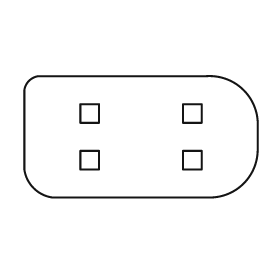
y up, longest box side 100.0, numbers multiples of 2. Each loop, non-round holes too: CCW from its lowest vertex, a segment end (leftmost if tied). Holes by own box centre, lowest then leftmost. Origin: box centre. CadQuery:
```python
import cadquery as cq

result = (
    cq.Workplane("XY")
    .moveTo(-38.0, -26.0)
    .lineTo(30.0, -26.0)
    .threePointArc((44.0, -20.0), (50.0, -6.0))
    .lineTo(50.0, 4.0)
    .threePointArc((44.0, 20.0), (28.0, 26.0))
    .lineTo(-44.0, 26.0)
    .threePointArc((-48.0, 24.0), (-50.0, 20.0))
    .lineTo(-50.0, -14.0)
    .threePointArc((-46.0, -22.0), (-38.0, -26.0))
    .close()
    .moveTo(-26.0, -14.0)
    .lineTo(-18.0, -14.0)
    .lineTo(-18.0, -6.0)
    .lineTo(-26.0, -6.0)
    .close()
    .moveTo(18.0, -14.0)
    .lineTo(26.0, -14.0)
    .lineTo(26.0, -6.0)
    .lineTo(18.0, -6.0)
    .close()
    .moveTo(-26.0, 6.0)
    .lineTo(-18.0, 6.0)
    .lineTo(-18.0, 14.0)
    .lineTo(-26.0, 14.0)
    .close()
    .moveTo(18.0, 6.0)
    .lineTo(26.0, 6.0)
    .lineTo(26.0, 14.0)
    .lineTo(18.0, 14.0)
    .close()
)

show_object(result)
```